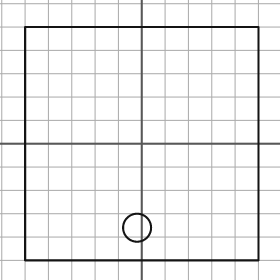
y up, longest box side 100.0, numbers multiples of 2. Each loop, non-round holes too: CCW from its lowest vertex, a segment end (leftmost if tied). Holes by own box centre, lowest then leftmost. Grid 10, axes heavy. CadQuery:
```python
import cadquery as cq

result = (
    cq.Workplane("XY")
    .moveTo(-50.0, -50.0)
    .lineTo(50.0, -50.0)
    .lineTo(50.0, 50.0)
    .lineTo(-50.0, 50.0)
    .close()
    .moveTo(-2.0, -36.0)
    .circle(6.0)
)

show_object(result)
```